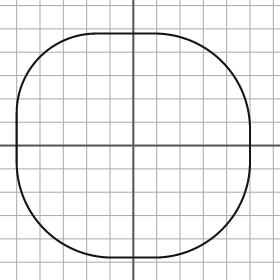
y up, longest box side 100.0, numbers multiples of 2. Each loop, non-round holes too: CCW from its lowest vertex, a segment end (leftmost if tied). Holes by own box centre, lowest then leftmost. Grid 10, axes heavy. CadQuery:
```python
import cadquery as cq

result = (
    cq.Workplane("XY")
    .moveTo(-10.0, -48.0)
    .lineTo(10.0, -48.0)
    .threePointArc((38.0, -36.0), (50.0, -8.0))
    .lineTo(50.0, 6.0)
    .threePointArc((38.0, 36.0), (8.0, 48.0))
    .lineTo(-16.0, 48.0)
    .threePointArc((-40.0, 38.0), (-50.0, 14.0))
    .lineTo(-50.0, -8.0)
    .threePointArc((-38.0, -36.0), (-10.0, -48.0))
    .close()
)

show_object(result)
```